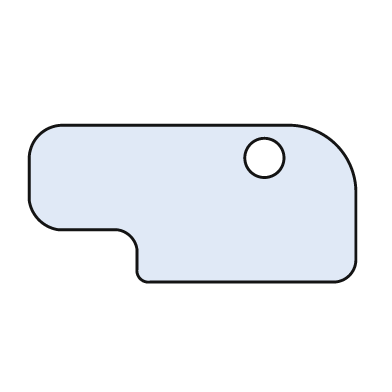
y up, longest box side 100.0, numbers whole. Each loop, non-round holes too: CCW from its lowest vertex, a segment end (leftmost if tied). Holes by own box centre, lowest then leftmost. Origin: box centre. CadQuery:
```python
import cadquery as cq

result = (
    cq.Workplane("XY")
    .moveTo(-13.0, -24.0)
    .lineTo(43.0, -24.0)
    .threePointArc((48.0, -22.0), (50.0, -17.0))
    .lineTo(50.0, 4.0)
    .threePointArc((44.0, 18.0), (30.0, 24.0))
    .lineTo(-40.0, 24.0)
    .threePointArc((-47.0, 21.0), (-50.0, 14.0))
    .lineTo(-50.0, 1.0)
    .threePointArc((-47.0, -5.0), (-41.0, -8.0))
    .lineTo(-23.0, -8.0)
    .threePointArc((-19.0, -10.0), (-17.0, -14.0))
    .lineTo(-17.0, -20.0)
    .threePointArc((-16.0, -23.0), (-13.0, -24.0))
    .close()
    .moveTo(22.0, 14.0)
    .circle(6.0)
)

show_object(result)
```